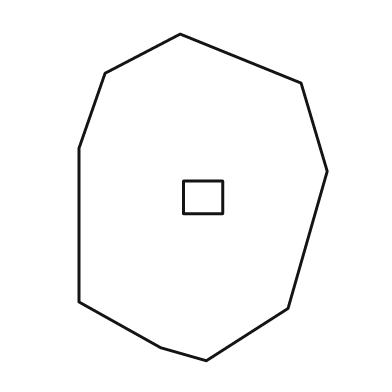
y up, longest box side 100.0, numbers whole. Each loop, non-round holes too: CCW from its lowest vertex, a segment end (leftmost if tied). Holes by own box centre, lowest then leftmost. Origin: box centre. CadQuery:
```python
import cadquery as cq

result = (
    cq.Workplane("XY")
    .moveTo(1.0, -50.0)
    .lineTo(26.0, -34.0)
    .lineTo(38.0, 8.0)
    .lineTo(30.0, 35.0)
    .lineTo(-7.0, 50.0)
    .lineTo(-30.0, 38.0)
    .lineTo(-38.0, 15.0)
    .lineTo(-38.0, -32.0)
    .lineTo(-13.0, -46.0)
    .close()
    .moveTo(-6.0, -5.0)
    .lineTo(6.0, -5.0)
    .lineTo(6.0, 5.0)
    .lineTo(-6.0, 5.0)
    .close()
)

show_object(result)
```